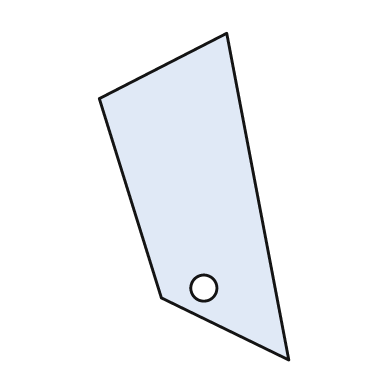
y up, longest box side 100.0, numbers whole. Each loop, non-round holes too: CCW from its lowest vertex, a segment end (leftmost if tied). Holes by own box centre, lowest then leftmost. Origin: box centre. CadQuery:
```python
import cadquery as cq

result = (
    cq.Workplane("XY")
    .moveTo(29.0, -50.0)
    .lineTo(10.0, 50.0)
    .lineTo(-29.0, 30.0)
    .lineTo(-10.0, -31.0)
    .close()
    .moveTo(3.0, -28.0)
    .circle(4.0)
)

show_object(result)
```